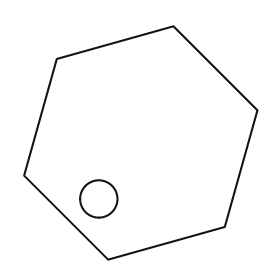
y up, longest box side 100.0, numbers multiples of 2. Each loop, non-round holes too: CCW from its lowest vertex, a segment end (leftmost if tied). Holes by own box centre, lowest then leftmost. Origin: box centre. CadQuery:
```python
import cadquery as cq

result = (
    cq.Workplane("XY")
    .moveTo(-14.0, -50.0)
    .lineTo(36.0, -36.0)
    .lineTo(50.0, 14.0)
    .lineTo(14.0, 50.0)
    .lineTo(-36.0, 36.0)
    .lineTo(-50.0, -14.0)
    .close()
    .moveTo(-18.0, -24.0)
    .circle(8.0)
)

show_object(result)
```